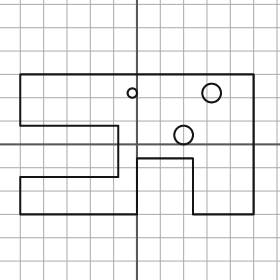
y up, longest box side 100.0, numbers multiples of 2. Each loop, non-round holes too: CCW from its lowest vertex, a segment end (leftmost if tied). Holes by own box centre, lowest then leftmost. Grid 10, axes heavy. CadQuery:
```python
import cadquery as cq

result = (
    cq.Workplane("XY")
    .moveTo(-50.0, -30.0)
    .lineTo(0.0, -30.0)
    .lineTo(0.0, -6.0)
    .lineTo(24.0, -6.0)
    .lineTo(24.0, -30.0)
    .lineTo(50.0, -30.0)
    .lineTo(50.0, 30.0)
    .lineTo(-50.0, 30.0)
    .lineTo(-50.0, 8.0)
    .lineTo(-8.0, 8.0)
    .lineTo(-8.0, -14.0)
    .lineTo(-50.0, -14.0)
    .close()
    .moveTo(20.0, 4.0)
    .circle(4.0)
    .moveTo(-2.0, 22.0)
    .circle(2.0)
    .moveTo(32.0, 22.0)
    .circle(4.0)
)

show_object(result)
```